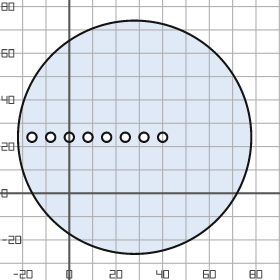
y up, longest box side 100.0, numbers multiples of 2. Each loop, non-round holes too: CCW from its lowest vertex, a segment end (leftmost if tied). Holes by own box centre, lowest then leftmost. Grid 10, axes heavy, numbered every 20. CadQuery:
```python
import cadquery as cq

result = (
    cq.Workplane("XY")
    .moveTo(28.0, 24.0)
    .circle(50.0)
    .moveTo(-16.0, 24.0)
    .circle(2.0)
    .moveTo(-8.0, 24.0)
    .circle(2.0)
    .moveTo(0.0, 24.0)
    .circle(2.0)
    .moveTo(8.0, 24.0)
    .circle(2.0)
    .moveTo(16.0, 24.0)
    .circle(2.0)
    .moveTo(24.0, 24.0)
    .circle(2.0)
    .moveTo(32.0, 24.0)
    .circle(2.0)
    .moveTo(40.0, 24.0)
    .circle(2.0)
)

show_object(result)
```